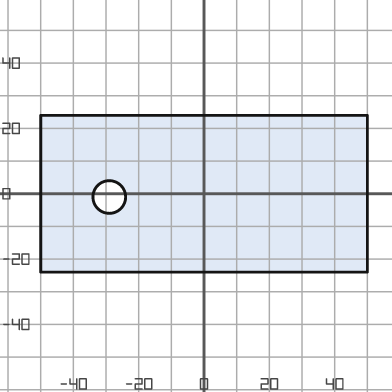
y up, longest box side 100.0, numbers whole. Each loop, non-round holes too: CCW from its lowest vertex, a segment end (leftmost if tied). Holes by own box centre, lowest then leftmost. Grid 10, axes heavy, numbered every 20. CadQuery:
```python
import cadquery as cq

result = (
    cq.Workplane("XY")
    .moveTo(-50.0, -24.0)
    .lineTo(50.0, -24.0)
    .lineTo(50.0, 24.0)
    .lineTo(-50.0, 24.0)
    .close()
    .moveTo(-29.0, -1.0)
    .circle(5.0)
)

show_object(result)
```